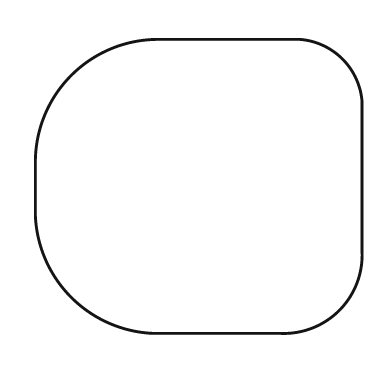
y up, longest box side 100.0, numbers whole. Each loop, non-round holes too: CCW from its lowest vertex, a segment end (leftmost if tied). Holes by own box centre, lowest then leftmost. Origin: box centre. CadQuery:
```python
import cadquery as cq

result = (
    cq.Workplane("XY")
    .moveTo(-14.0, -45.0)
    .lineTo(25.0, -45.0)
    .threePointArc((43.0, -38.0), (50.0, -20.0))
    .lineTo(50.0, 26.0)
    .threePointArc((44.0, 39.0), (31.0, 45.0))
    .lineTo(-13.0, 45.0)
    .threePointArc((-39.0, 34.0), (-50.0, 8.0))
    .lineTo(-50.0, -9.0)
    .threePointArc((-39.0, -34.0), (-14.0, -45.0))
    .close()
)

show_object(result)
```